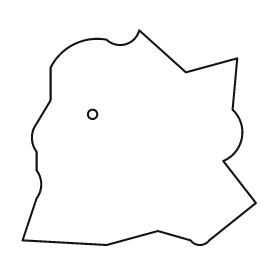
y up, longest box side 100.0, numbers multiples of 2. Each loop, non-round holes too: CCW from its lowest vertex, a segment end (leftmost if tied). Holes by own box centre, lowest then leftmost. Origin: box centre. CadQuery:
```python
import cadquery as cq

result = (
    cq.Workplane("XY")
    .moveTo(-14.0, -46.0)
    .lineTo(8.0, -40.0)
    .lineTo(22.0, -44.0)
    .threePointArc((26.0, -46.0), (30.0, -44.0))
    .lineTo(50.0, -28.0)
    .lineTo(36.0, -10.0)
    .threePointArc((44.0, 0.0), (40.0, 12.0))
    .lineTo(42.0, 34.0)
    .lineTo(20.0, 28.0)
    .lineTo(0.0, 46.0)
    .threePointArc((-6.0, 40.0), (-14.0, 42.0))
    .threePointArc((-28.0, 40.0), (-38.0, 30.0))
    .lineTo(-38.0, 16.0)
    .lineTo(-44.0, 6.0)
    .threePointArc((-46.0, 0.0), (-44.0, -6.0))
    .lineTo(-44.0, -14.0)
    .threePointArc((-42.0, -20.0), (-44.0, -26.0))
    .lineTo(-50.0, -44.0)
    .close()
    .moveTo(-20.0, 10.0)
    .circle(2.0)
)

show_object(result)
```